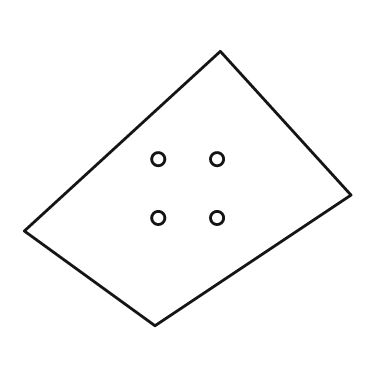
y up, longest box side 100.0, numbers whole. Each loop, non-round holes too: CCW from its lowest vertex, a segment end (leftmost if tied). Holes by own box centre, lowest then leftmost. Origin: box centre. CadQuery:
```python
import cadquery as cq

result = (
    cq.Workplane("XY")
    .moveTo(-10.0, -42.0)
    .lineTo(50.0, -2.0)
    .lineTo(10.0, 42.0)
    .lineTo(-50.0, -13.0)
    .close()
    .moveTo(-9.0, -9.0)
    .circle(2.0)
    .moveTo(9.0, -9.0)
    .circle(2.0)
    .moveTo(-9.0, 9.0)
    .circle(2.0)
    .moveTo(9.0, 9.0)
    .circle(2.0)
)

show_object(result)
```